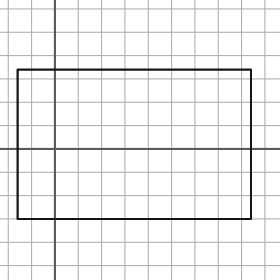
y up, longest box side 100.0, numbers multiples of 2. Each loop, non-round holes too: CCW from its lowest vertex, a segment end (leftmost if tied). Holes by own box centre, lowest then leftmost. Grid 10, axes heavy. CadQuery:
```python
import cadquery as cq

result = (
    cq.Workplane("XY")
    .moveTo(-16.0, -30.0)
    .lineTo(84.0, -30.0)
    .lineTo(84.0, 34.0)
    .lineTo(-16.0, 34.0)
    .close()
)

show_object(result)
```